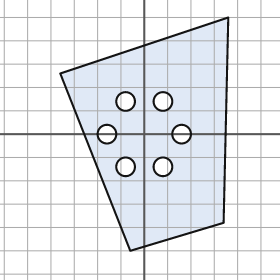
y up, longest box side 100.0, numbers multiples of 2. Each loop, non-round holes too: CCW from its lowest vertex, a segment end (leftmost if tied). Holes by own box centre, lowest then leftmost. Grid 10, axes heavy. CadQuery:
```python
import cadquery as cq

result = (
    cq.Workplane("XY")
    .moveTo(-6.0, -50.0)
    .lineTo(34.0, -38.0)
    .lineTo(36.0, 50.0)
    .lineTo(-36.0, 26.0)
    .close()
    .moveTo(-8.0, -14.0)
    .circle(4.0)
    .moveTo(8.0, -14.0)
    .circle(4.0)
    .moveTo(-16.0, 0.0)
    .circle(4.0)
    .moveTo(16.0, 0.0)
    .circle(4.0)
    .moveTo(-8.0, 14.0)
    .circle(4.0)
    .moveTo(8.0, 14.0)
    .circle(4.0)
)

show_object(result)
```